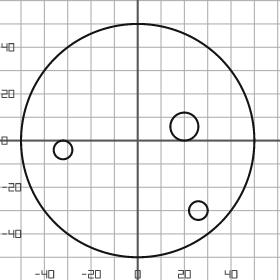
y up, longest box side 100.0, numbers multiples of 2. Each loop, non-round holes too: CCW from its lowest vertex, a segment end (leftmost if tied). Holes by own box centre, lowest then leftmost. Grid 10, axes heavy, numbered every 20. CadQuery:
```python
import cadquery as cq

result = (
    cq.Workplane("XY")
    .moveTo(0.0, 0.0)
    .circle(50.0)
    .moveTo(26.0, -30.0)
    .circle(4.0)
    .moveTo(-32.0, -4.0)
    .circle(4.0)
    .moveTo(20.0, 6.0)
    .circle(6.0)
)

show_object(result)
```